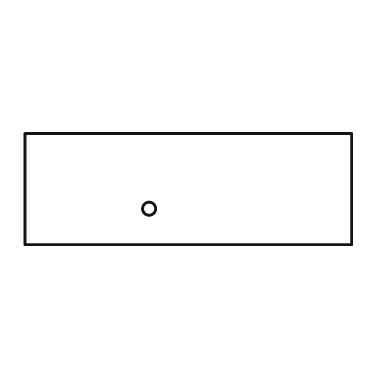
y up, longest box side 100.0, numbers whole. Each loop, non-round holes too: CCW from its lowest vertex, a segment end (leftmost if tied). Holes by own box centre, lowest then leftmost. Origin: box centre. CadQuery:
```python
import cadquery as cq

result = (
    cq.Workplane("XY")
    .moveTo(-50.0, -17.0)
    .lineTo(50.0, -17.0)
    .lineTo(50.0, 17.0)
    .lineTo(-50.0, 17.0)
    .close()
    .moveTo(-12.0, -6.0)
    .circle(2.0)
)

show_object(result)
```